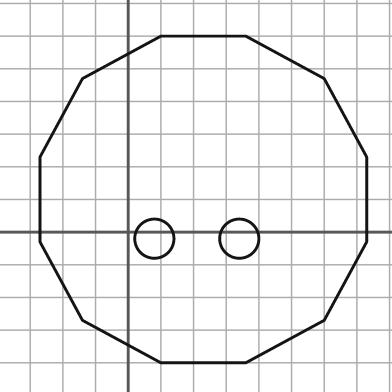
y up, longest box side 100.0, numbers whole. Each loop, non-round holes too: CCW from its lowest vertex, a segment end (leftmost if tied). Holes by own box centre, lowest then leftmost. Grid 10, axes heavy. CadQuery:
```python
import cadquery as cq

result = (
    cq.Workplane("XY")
    .moveTo(10.0, -40.0)
    .lineTo(36.0, -40.0)
    .lineTo(60.0, -27.0)
    .lineTo(73.0, -3.0)
    .lineTo(73.0, 23.0)
    .lineTo(60.0, 47.0)
    .lineTo(36.0, 60.0)
    .lineTo(10.0, 60.0)
    .lineTo(-14.0, 47.0)
    .lineTo(-27.0, 23.0)
    .lineTo(-27.0, -3.0)
    .lineTo(-14.0, -27.0)
    .close()
    .moveTo(8.0, -2.0)
    .circle(6.0)
    .moveTo(34.0, -2.0)
    .circle(6.0)
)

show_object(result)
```